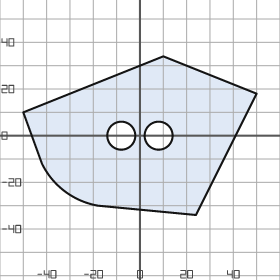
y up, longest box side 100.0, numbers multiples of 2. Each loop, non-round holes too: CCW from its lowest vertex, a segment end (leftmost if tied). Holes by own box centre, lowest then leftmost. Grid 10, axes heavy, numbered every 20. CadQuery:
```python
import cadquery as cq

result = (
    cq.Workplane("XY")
    .moveTo(24.0, -34.0)
    .lineTo(50.0, 18.0)
    .lineTo(10.0, 34.0)
    .lineTo(-50.0, 10.0)
    .lineTo(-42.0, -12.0)
    .threePointArc((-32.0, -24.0), (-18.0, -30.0))
    .close()
    .moveTo(-8.0, 0.0)
    .circle(6.0)
    .moveTo(8.0, 0.0)
    .circle(6.0)
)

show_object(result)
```